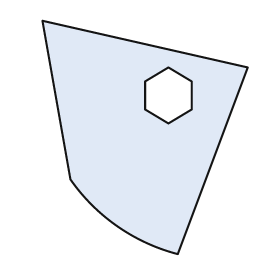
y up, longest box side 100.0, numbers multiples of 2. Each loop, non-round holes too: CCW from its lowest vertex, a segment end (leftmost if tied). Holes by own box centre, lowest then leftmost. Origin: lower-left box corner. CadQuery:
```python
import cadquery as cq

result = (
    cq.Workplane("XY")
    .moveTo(58.0, 0.0)
    .lineTo(88.0, 80.0)
    .lineTo(0.0, 100.0)
    .lineTo(12.0, 32.0)
    .threePointArc((32.0, 12.0), (58.0, 0.0))
    .close()
    .moveTo(54.0, 56.0)
    .lineTo(64.0, 62.0)
    .lineTo(64.0, 74.0)
    .lineTo(54.0, 80.0)
    .lineTo(44.0, 74.0)
    .lineTo(44.0, 62.0)
    .close()
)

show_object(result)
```